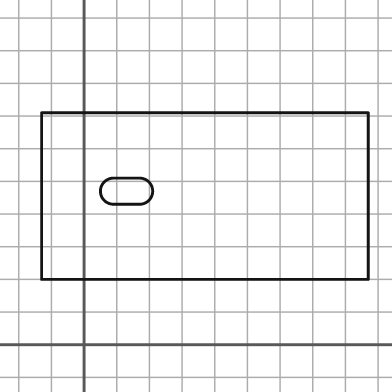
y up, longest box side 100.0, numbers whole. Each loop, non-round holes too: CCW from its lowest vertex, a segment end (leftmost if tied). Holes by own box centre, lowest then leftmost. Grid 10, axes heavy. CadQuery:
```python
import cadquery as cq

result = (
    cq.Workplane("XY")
    .moveTo(-13.0, 20.0)
    .lineTo(87.0, 20.0)
    .lineTo(87.0, 71.0)
    .lineTo(-13.0, 71.0)
    .close()
    .moveTo(9.0, 43.0)
    .lineTo(17.0, 43.0)
    .threePointArc((21.0, 47.0), (17.0, 51.0))
    .lineTo(9.0, 51.0)
    .threePointArc((5.0, 47.0), (9.0, 43.0))
    .close()
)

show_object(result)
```